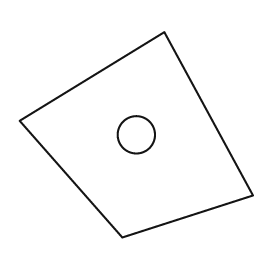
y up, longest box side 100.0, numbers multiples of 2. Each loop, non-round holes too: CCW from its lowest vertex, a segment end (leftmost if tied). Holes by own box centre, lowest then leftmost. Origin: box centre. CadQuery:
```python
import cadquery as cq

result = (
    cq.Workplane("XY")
    .moveTo(-6.0, -44.0)
    .lineTo(50.0, -26.0)
    .lineTo(12.0, 44.0)
    .lineTo(-50.0, 6.0)
    .close()
    .moveTo(0.0, 0.0)
    .circle(8.0)
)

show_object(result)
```